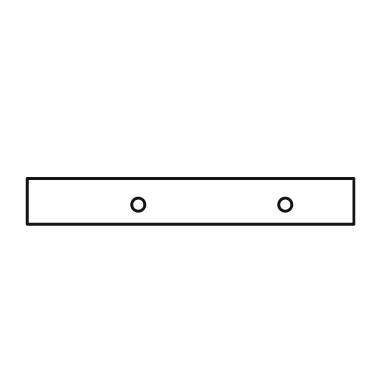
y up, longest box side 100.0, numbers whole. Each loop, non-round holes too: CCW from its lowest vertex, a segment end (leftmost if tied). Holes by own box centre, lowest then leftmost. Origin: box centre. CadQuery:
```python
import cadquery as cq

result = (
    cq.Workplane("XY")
    .moveTo(-50.0, -7.0)
    .lineTo(50.0, -7.0)
    .lineTo(50.0, 7.0)
    .lineTo(-50.0, 7.0)
    .close()
    .moveTo(-16.0, -1.0)
    .circle(2.0)
    .moveTo(29.0, -1.0)
    .circle(2.0)
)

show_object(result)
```